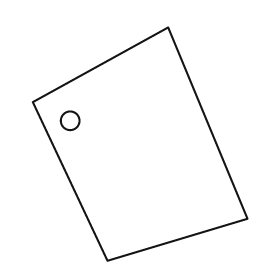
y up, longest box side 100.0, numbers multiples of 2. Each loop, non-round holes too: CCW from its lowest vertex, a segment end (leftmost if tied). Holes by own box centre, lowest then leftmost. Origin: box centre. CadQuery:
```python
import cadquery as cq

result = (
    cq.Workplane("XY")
    .moveTo(-14.0, -50.0)
    .lineTo(46.0, -32.0)
    .lineTo(12.0, 50.0)
    .lineTo(-46.0, 18.0)
    .close()
    .moveTo(-30.0, 10.0)
    .circle(4.0)
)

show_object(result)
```